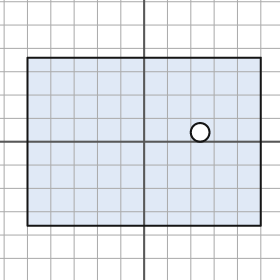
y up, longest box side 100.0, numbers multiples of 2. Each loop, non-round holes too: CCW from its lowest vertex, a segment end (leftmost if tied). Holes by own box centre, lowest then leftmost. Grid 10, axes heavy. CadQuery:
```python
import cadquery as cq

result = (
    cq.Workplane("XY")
    .moveTo(-50.0, -36.0)
    .lineTo(50.0, -36.0)
    .lineTo(50.0, 36.0)
    .lineTo(-50.0, 36.0)
    .close()
    .moveTo(24.0, 4.0)
    .circle(4.0)
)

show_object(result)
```